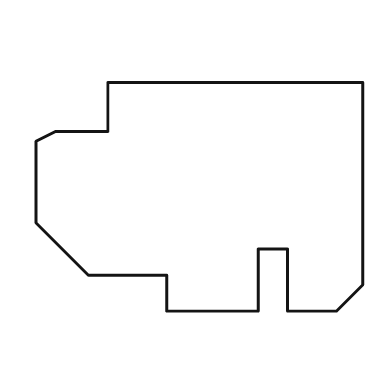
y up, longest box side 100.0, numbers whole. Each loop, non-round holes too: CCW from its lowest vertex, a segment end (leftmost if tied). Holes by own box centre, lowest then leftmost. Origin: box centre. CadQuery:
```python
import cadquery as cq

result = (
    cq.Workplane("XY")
    .moveTo(-10.0, -35.0)
    .lineTo(18.0, -35.0)
    .lineTo(18.0, -16.0)
    .lineTo(27.0, -16.0)
    .lineTo(27.0, -35.0)
    .lineTo(42.0, -35.0)
    .lineTo(50.0, -27.0)
    .lineTo(50.0, 35.0)
    .lineTo(-28.0, 35.0)
    .lineTo(-28.0, 20.0)
    .lineTo(-44.0, 20.0)
    .lineTo(-50.0, 17.0)
    .lineTo(-50.0, -8.0)
    .lineTo(-34.0, -24.0)
    .lineTo(-10.0, -24.0)
    .close()
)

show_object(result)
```